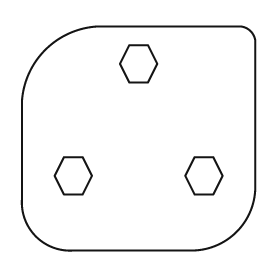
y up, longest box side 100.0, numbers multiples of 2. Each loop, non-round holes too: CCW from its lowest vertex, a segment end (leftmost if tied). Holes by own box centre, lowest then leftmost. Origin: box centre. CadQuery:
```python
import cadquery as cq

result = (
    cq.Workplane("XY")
    .moveTo(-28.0, -48.0)
    .lineTo(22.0, -48.0)
    .threePointArc((42.0, -40.0), (50.0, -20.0))
    .lineTo(50.0, 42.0)
    .threePointArc((48.0, 46.0), (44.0, 48.0))
    .lineTo(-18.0, 48.0)
    .threePointArc((-40.0, 38.0), (-50.0, 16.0))
    .lineTo(-50.0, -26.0)
    .threePointArc((-44.0, -42.0), (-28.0, -48.0))
    .close()
    .moveTo(-32.0, -24.0)
    .lineTo(-24.0, -24.0)
    .lineTo(-20.0, -16.0)
    .lineTo(-24.0, -8.0)
    .lineTo(-32.0, -8.0)
    .lineTo(-36.0, -16.0)
    .close()
    .moveTo(24.0, -24.0)
    .lineTo(32.0, -24.0)
    .lineTo(36.0, -16.0)
    .lineTo(32.0, -8.0)
    .lineTo(24.0, -8.0)
    .lineTo(20.0, -16.0)
    .close()
    .moveTo(-4.0, 24.0)
    .lineTo(4.0, 24.0)
    .lineTo(8.0, 32.0)
    .lineTo(4.0, 40.0)
    .lineTo(-4.0, 40.0)
    .lineTo(-8.0, 32.0)
    .close()
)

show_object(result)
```